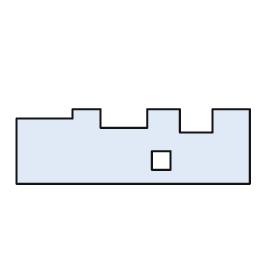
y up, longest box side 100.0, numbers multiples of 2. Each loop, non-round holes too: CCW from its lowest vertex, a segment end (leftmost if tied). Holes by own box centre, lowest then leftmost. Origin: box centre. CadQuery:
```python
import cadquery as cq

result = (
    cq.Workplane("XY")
    .moveTo(-50.0, -16.0)
    .lineTo(50.0, -16.0)
    .lineTo(50.0, 16.0)
    .lineTo(34.0, 16.0)
    .lineTo(34.0, 6.0)
    .lineTo(20.0, 6.0)
    .lineTo(20.0, 16.0)
    .lineTo(6.0, 16.0)
    .lineTo(6.0, 8.0)
    .lineTo(-14.0, 8.0)
    .lineTo(-14.0, 16.0)
    .lineTo(-26.0, 16.0)
    .lineTo(-26.0, 12.0)
    .lineTo(-50.0, 12.0)
    .close()
    .moveTo(8.0, -10.0)
    .lineTo(16.0, -10.0)
    .lineTo(16.0, -2.0)
    .lineTo(8.0, -2.0)
    .close()
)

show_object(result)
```